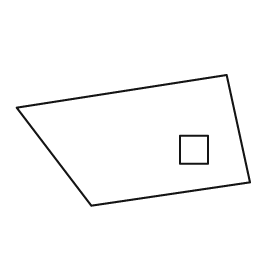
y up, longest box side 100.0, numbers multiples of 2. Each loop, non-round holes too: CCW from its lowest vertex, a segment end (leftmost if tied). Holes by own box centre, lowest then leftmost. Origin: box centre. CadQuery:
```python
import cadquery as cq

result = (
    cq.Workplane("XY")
    .moveTo(-18.0, -28.0)
    .lineTo(50.0, -18.0)
    .lineTo(40.0, 28.0)
    .lineTo(-50.0, 14.0)
    .close()
    .moveTo(20.0, -10.0)
    .lineTo(32.0, -10.0)
    .lineTo(32.0, 2.0)
    .lineTo(20.0, 2.0)
    .close()
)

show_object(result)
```